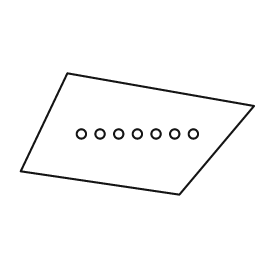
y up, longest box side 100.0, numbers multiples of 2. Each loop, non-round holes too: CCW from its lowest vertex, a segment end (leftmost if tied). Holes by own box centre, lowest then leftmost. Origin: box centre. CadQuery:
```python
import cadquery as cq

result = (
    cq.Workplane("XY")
    .moveTo(18.0, -26.0)
    .lineTo(50.0, 12.0)
    .lineTo(-30.0, 26.0)
    .lineTo(-50.0, -16.0)
    .close()
    .moveTo(-24.0, 0.0)
    .circle(2.0)
    .moveTo(-16.0, 0.0)
    .circle(2.0)
    .moveTo(-8.0, 0.0)
    .circle(2.0)
    .moveTo(0.0, 0.0)
    .circle(2.0)
    .moveTo(8.0, 0.0)
    .circle(2.0)
    .moveTo(16.0, 0.0)
    .circle(2.0)
    .moveTo(24.0, 0.0)
    .circle(2.0)
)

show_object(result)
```